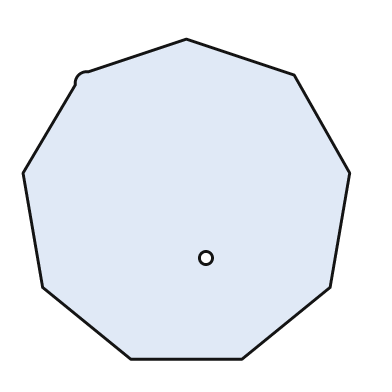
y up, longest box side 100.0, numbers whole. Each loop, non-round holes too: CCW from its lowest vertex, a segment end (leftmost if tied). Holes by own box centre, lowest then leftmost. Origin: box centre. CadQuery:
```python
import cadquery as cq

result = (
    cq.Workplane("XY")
    .moveTo(-17.0, -49.0)
    .lineTo(17.0, -49.0)
    .lineTo(44.0, -27.0)
    .lineTo(50.0, 8.0)
    .lineTo(33.0, 38.0)
    .lineTo(0.0, 49.0)
    .lineTo(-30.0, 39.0)
    .threePointArc((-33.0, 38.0), (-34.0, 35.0))
    .lineTo(-50.0, 8.0)
    .lineTo(-44.0, -27.0)
    .close()
    .moveTo(6.0, -18.0)
    .circle(2.0)
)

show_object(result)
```